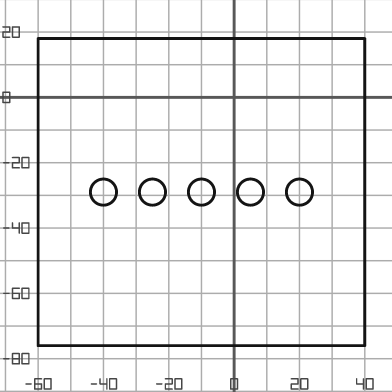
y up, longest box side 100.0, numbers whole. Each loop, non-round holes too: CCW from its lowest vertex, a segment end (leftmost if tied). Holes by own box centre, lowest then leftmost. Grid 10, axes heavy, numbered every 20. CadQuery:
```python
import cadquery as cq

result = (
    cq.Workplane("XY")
    .moveTo(-60.0, -76.0)
    .lineTo(40.0, -76.0)
    .lineTo(40.0, 18.0)
    .lineTo(-60.0, 18.0)
    .close()
    .moveTo(-40.0, -29.0)
    .circle(4.0)
    .moveTo(-25.0, -29.0)
    .circle(4.0)
    .moveTo(-10.0, -29.0)
    .circle(4.0)
    .moveTo(5.0, -29.0)
    .circle(4.0)
    .moveTo(20.0, -29.0)
    .circle(4.0)
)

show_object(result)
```